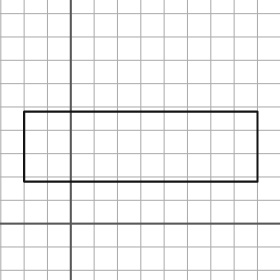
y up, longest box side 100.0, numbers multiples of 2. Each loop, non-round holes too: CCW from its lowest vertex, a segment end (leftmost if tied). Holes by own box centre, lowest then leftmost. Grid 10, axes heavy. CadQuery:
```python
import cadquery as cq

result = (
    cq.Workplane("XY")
    .moveTo(-20.0, 18.0)
    .lineTo(80.0, 18.0)
    .lineTo(80.0, 48.0)
    .lineTo(-20.0, 48.0)
    .close()
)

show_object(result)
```